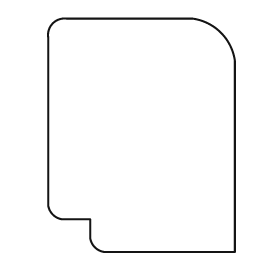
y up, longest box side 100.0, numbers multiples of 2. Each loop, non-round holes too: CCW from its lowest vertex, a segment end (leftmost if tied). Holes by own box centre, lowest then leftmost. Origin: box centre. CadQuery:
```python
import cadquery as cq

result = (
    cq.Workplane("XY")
    .moveTo(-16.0, -50.0)
    .lineTo(40.0, -50.0)
    .lineTo(40.0, 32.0)
    .threePointArc((34.0, 44.0), (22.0, 50.0))
    .lineTo(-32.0, 50.0)
    .threePointArc((-38.0, 48.0), (-40.0, 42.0))
    .lineTo(-40.0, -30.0)
    .threePointArc((-38.0, -34.0), (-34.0, -36.0))
    .lineTo(-22.0, -36.0)
    .lineTo(-22.0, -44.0)
    .threePointArc((-20.0, -48.0), (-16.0, -50.0))
    .close()
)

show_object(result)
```